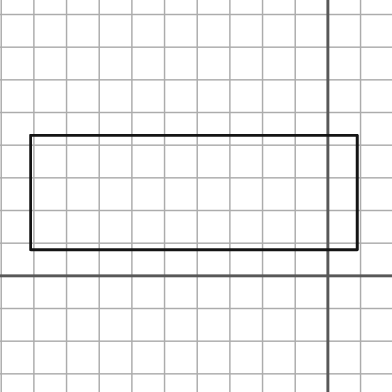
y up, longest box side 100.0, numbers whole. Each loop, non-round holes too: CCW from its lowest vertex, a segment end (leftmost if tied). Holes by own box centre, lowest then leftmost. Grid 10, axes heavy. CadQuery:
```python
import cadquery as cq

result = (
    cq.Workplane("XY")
    .moveTo(-91.0, 8.0)
    .lineTo(9.0, 8.0)
    .lineTo(9.0, 43.0)
    .lineTo(-91.0, 43.0)
    .close()
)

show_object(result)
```